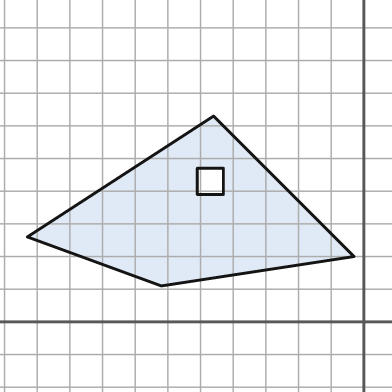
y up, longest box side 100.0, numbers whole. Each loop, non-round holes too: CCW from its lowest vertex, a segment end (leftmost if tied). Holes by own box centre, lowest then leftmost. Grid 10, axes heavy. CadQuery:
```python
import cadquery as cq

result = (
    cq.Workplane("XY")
    .moveTo(-62.0, 11.0)
    .lineTo(-3.0, 20.0)
    .lineTo(-46.0, 63.0)
    .lineTo(-103.0, 26.0)
    .close()
    .moveTo(-51.0, 39.0)
    .lineTo(-43.0, 39.0)
    .lineTo(-43.0, 47.0)
    .lineTo(-51.0, 47.0)
    .close()
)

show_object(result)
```